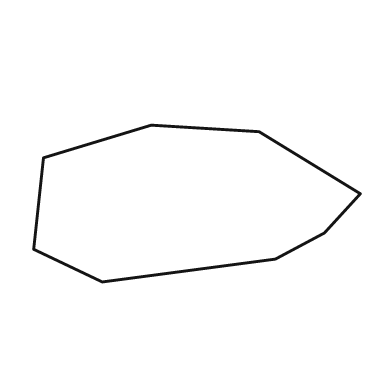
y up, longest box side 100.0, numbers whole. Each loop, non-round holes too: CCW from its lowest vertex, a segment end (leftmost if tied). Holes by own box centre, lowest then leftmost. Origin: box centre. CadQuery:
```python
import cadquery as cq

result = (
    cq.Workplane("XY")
    .moveTo(-29.0, -24.0)
    .lineTo(24.0, -17.0)
    .lineTo(39.0, -9.0)
    .lineTo(50.0, 3.0)
    .lineTo(19.0, 22.0)
    .lineTo(-14.0, 24.0)
    .lineTo(-47.0, 14.0)
    .lineTo(-50.0, -14.0)
    .close()
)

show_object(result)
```